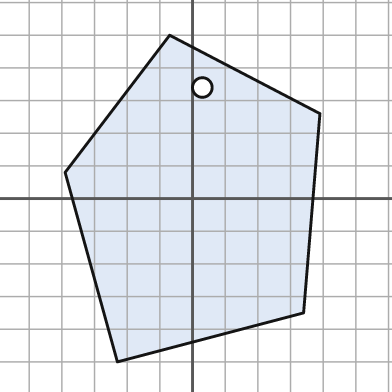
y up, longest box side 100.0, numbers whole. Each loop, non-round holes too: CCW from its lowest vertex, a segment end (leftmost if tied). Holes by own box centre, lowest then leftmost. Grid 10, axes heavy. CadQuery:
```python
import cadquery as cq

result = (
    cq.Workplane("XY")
    .moveTo(-23.0, -50.0)
    .lineTo(34.0, -35.0)
    .lineTo(39.0, 26.0)
    .lineTo(-7.0, 50.0)
    .lineTo(-39.0, 8.0)
    .close()
    .moveTo(3.0, 34.0)
    .circle(3.0)
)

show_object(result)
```